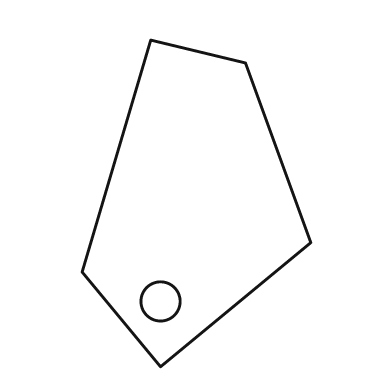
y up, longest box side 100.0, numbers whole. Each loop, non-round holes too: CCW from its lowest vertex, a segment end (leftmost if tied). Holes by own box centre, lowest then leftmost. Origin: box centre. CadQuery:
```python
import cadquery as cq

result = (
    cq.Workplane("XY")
    .moveTo(-11.0, -50.0)
    .lineTo(35.0, -12.0)
    .lineTo(15.0, 43.0)
    .lineTo(-14.0, 50.0)
    .lineTo(-35.0, -21.0)
    .close()
    .moveTo(-11.0, -30.0)
    .circle(6.0)
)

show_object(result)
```